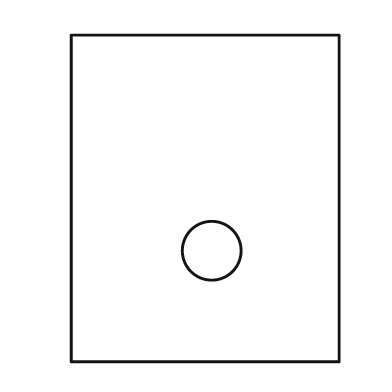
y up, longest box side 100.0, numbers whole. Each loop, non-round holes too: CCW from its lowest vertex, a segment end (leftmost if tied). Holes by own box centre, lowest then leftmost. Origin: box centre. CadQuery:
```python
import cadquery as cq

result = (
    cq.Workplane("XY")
    .moveTo(-41.0, -50.0)
    .lineTo(41.0, -50.0)
    .lineTo(41.0, 50.0)
    .lineTo(-41.0, 50.0)
    .close()
    .moveTo(2.0, -16.0)
    .circle(9.0)
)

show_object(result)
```